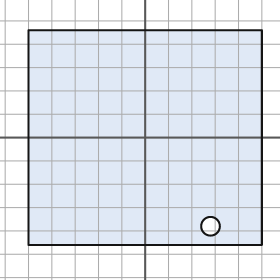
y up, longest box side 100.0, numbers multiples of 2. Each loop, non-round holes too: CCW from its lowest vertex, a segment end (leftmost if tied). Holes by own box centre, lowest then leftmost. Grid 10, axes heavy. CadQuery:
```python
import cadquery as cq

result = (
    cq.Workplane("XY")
    .moveTo(-50.0, -46.0)
    .lineTo(50.0, -46.0)
    .lineTo(50.0, 46.0)
    .lineTo(-50.0, 46.0)
    .close()
    .moveTo(28.0, -38.0)
    .circle(4.0)
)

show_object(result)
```